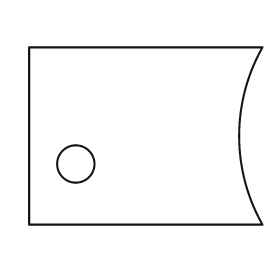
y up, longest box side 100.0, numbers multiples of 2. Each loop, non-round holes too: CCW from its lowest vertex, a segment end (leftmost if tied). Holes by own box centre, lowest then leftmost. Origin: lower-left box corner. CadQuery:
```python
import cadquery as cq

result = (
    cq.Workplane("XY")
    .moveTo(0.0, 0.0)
    .lineTo(100.0, 0.0)
    .threePointArc((90.0, 38.0), (100.0, 76.0))
    .lineTo(0.0, 76.0)
    .close()
    .moveTo(20.0, 26.0)
    .circle(8.0)
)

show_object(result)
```